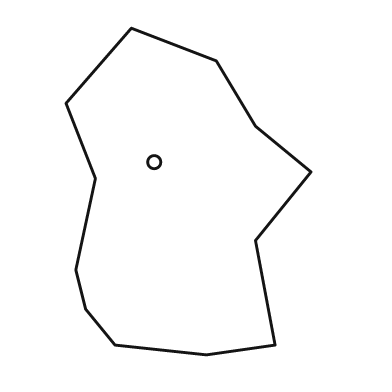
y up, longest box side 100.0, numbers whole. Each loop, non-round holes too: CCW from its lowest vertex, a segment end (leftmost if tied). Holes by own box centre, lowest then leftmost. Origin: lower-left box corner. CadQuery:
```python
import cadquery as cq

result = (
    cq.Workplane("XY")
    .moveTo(43.0, 0.0)
    .lineTo(64.0, 3.0)
    .lineTo(58.0, 35.0)
    .lineTo(75.0, 56.0)
    .lineTo(58.0, 70.0)
    .lineTo(46.0, 90.0)
    .lineTo(20.0, 100.0)
    .lineTo(0.0, 77.0)
    .lineTo(9.0, 54.0)
    .lineTo(3.0, 26.0)
    .lineTo(6.0, 14.0)
    .lineTo(15.0, 3.0)
    .close()
    .moveTo(27.0, 59.0)
    .circle(2.0)
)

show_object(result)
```